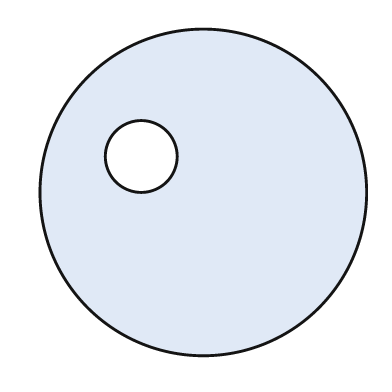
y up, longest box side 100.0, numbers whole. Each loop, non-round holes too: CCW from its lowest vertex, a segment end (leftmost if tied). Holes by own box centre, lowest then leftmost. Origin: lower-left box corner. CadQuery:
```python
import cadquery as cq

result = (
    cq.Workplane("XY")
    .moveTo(50.0, 50.0)
    .circle(50.0)
    .moveTo(31.0, 61.0)
    .circle(11.0)
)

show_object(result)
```